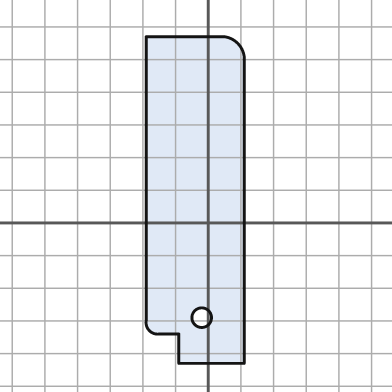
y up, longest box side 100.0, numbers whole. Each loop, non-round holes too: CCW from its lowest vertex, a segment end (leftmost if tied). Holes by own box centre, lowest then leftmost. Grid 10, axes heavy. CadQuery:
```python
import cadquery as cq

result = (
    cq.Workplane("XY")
    .moveTo(-9.0, -43.0)
    .lineTo(11.0, -43.0)
    .lineTo(11.0, 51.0)
    .threePointArc((9.0, 55.0), (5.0, 57.0))
    .lineTo(-19.0, 57.0)
    .lineTo(-19.0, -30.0)
    .threePointArc((-18.0, -33.0), (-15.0, -34.0))
    .lineTo(-9.0, -34.0)
    .close()
    .moveTo(-2.0, -29.0)
    .circle(3.0)
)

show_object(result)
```